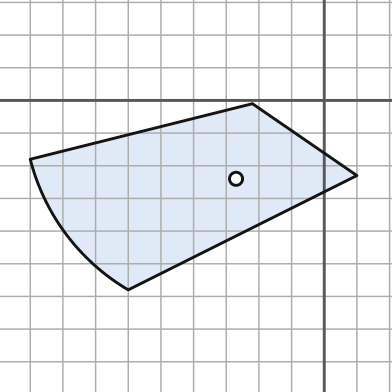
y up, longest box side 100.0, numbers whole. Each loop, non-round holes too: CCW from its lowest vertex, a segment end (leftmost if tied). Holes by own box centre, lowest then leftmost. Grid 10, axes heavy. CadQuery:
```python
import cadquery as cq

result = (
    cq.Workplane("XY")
    .moveTo(-60.0, -58.0)
    .lineTo(10.0, -23.0)
    .lineTo(-22.0, -1.0)
    .lineTo(-90.0, -18.0)
    .threePointArc((-79.0, -41.0), (-60.0, -58.0))
    .close()
    .moveTo(-27.0, -24.0)
    .circle(2.0)
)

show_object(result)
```